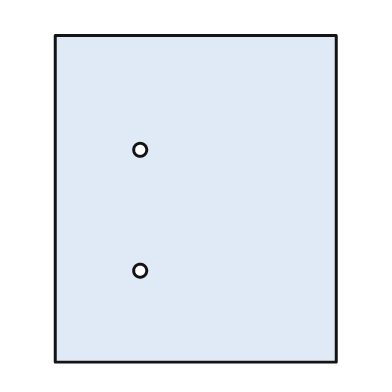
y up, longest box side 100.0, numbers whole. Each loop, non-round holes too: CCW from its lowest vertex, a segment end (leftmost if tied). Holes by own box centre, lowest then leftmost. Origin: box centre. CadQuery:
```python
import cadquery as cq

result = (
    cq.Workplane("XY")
    .moveTo(-43.0, -50.0)
    .lineTo(43.0, -50.0)
    .lineTo(43.0, 50.0)
    .lineTo(-43.0, 50.0)
    .close()
    .moveTo(-17.0, -22.0)
    .circle(2.0)
    .moveTo(-17.0, 15.0)
    .circle(2.0)
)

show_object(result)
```